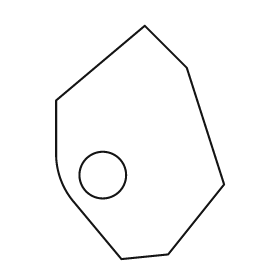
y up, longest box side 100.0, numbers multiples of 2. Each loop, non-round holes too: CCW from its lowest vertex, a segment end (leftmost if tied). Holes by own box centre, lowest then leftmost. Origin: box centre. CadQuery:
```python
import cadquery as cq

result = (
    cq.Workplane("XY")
    .moveTo(-8.0, -50.0)
    .lineTo(12.0, -48.0)
    .lineTo(36.0, -18.0)
    .lineTo(20.0, 32.0)
    .lineTo(2.0, 50.0)
    .lineTo(-36.0, 18.0)
    .lineTo(-36.0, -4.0)
    .threePointArc((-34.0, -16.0), (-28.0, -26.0))
    .close()
    .moveTo(-16.0, -14.0)
    .circle(10.0)
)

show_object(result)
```